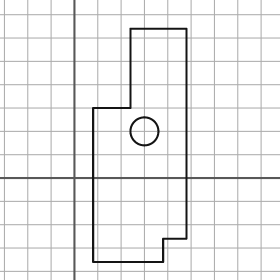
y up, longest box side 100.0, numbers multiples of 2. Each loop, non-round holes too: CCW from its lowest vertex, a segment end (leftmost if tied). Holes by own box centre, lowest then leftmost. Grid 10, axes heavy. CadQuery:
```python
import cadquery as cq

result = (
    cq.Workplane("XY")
    .moveTo(8.0, -36.0)
    .lineTo(38.0, -36.0)
    .lineTo(38.0, -26.0)
    .lineTo(48.0, -26.0)
    .lineTo(48.0, 64.0)
    .lineTo(24.0, 64.0)
    .lineTo(24.0, 30.0)
    .lineTo(8.0, 30.0)
    .close()
    .moveTo(30.0, 20.0)
    .circle(6.0)
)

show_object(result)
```